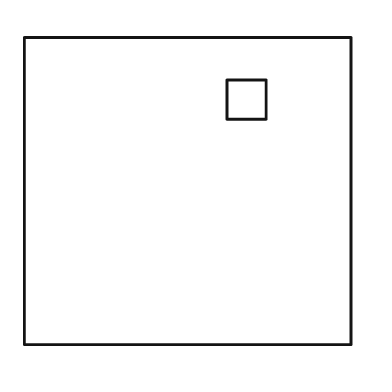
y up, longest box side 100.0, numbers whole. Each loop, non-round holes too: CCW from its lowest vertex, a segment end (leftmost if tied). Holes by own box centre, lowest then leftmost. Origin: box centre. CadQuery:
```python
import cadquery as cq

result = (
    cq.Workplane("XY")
    .moveTo(-50.0, -47.0)
    .lineTo(50.0, -47.0)
    .lineTo(50.0, 47.0)
    .lineTo(-50.0, 47.0)
    .close()
    .moveTo(12.0, 22.0)
    .lineTo(24.0, 22.0)
    .lineTo(24.0, 34.0)
    .lineTo(12.0, 34.0)
    .close()
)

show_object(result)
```